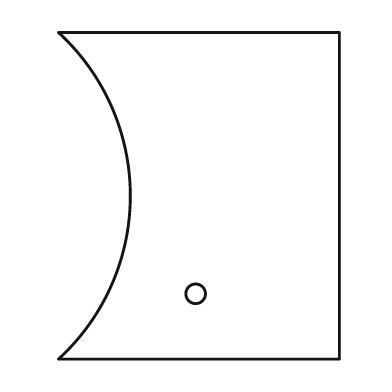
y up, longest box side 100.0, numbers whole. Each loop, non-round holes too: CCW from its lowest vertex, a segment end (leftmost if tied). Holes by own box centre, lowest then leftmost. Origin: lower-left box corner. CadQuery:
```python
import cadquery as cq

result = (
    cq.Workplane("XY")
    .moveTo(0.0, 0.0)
    .lineTo(86.0, 0.0)
    .lineTo(86.0, 100.0)
    .lineTo(0.0, 100.0)
    .threePointArc((22.0, 50.0), (0.0, 0.0))
    .close()
    .moveTo(42.0, 20.0)
    .circle(3.0)
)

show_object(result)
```